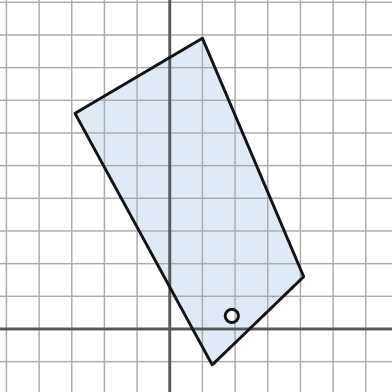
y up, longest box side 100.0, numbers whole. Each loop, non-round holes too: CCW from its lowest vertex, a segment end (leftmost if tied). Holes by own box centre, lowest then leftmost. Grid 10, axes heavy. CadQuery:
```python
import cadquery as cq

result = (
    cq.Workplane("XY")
    .moveTo(13.0, -11.0)
    .lineTo(41.0, 16.0)
    .lineTo(10.0, 89.0)
    .lineTo(-29.0, 66.0)
    .close()
    .moveTo(19.0, 4.0)
    .circle(2.0)
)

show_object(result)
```